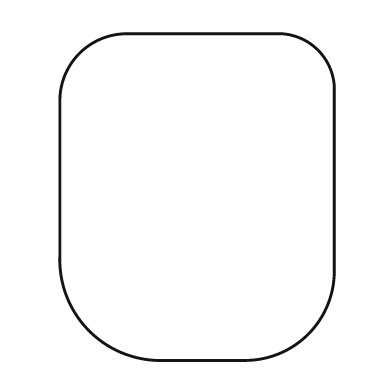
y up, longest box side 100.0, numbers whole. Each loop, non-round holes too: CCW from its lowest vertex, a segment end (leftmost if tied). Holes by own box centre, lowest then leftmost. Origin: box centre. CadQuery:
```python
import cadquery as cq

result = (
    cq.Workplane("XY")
    .moveTo(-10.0, -50.0)
    .lineTo(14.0, -50.0)
    .threePointArc((34.0, -42.0), (42.0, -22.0))
    .lineTo(42.0, 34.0)
    .threePointArc((37.0, 45.0), (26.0, 50.0))
    .lineTo(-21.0, 50.0)
    .threePointArc((-36.0, 44.0), (-42.0, 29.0))
    .lineTo(-42.0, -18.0)
    .threePointArc((-33.0, -41.0), (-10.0, -50.0))
    .close()
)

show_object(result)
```